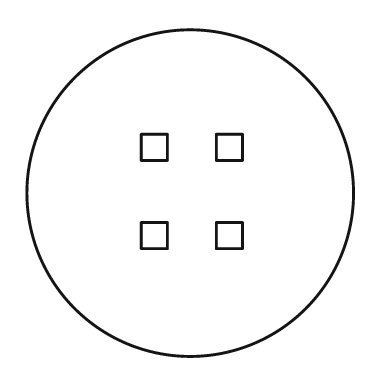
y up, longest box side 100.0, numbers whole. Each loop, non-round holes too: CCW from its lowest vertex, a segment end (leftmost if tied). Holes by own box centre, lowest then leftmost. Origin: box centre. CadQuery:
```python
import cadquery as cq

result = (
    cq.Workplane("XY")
    .moveTo(0.0, 0.0)
    .circle(50.0)
    .moveTo(-15.0, -17.0)
    .lineTo(-7.0, -17.0)
    .lineTo(-7.0, -9.0)
    .lineTo(-15.0, -9.0)
    .close()
    .moveTo(8.0, -17.0)
    .lineTo(16.0, -17.0)
    .lineTo(16.0, -9.0)
    .lineTo(8.0, -9.0)
    .close()
    .moveTo(-15.0, 10.0)
    .lineTo(-7.0, 10.0)
    .lineTo(-7.0, 18.0)
    .lineTo(-15.0, 18.0)
    .close()
    .moveTo(8.0, 10.0)
    .lineTo(16.0, 10.0)
    .lineTo(16.0, 18.0)
    .lineTo(8.0, 18.0)
    .close()
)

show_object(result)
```